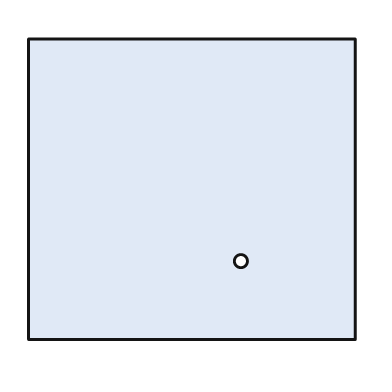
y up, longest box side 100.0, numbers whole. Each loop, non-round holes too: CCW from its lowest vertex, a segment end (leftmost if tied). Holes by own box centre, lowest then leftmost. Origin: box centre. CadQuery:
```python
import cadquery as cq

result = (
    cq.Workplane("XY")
    .moveTo(-50.0, -46.0)
    .lineTo(50.0, -46.0)
    .lineTo(50.0, 46.0)
    .lineTo(-50.0, 46.0)
    .close()
    .moveTo(15.0, -22.0)
    .circle(2.0)
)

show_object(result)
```